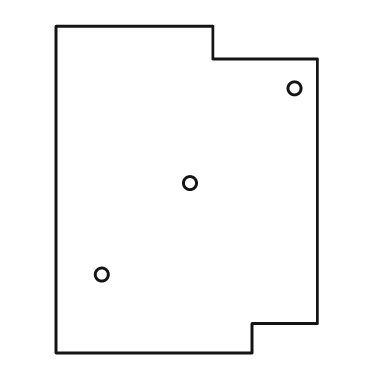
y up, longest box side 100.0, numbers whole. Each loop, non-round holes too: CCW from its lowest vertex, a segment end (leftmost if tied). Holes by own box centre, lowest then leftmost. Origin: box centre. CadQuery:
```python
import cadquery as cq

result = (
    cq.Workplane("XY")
    .moveTo(-40.0, -50.0)
    .lineTo(20.0, -50.0)
    .lineTo(20.0, -41.0)
    .lineTo(40.0, -41.0)
    .lineTo(40.0, 40.0)
    .lineTo(8.0, 40.0)
    .lineTo(8.0, 50.0)
    .lineTo(-40.0, 50.0)
    .close()
    .moveTo(-26.0, -26.0)
    .circle(2.0)
    .moveTo(1.0, 2.0)
    .circle(2.0)
    .moveTo(33.0, 31.0)
    .circle(2.0)
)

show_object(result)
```